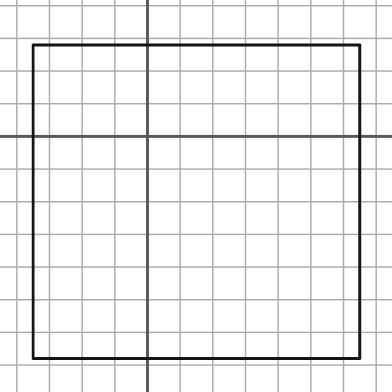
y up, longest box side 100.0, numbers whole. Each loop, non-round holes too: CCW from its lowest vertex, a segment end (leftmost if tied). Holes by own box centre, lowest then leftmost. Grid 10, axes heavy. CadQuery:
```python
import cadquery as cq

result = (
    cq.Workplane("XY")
    .moveTo(-35.0, -68.0)
    .lineTo(65.0, -68.0)
    .lineTo(65.0, 28.0)
    .lineTo(-35.0, 28.0)
    .close()
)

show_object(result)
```